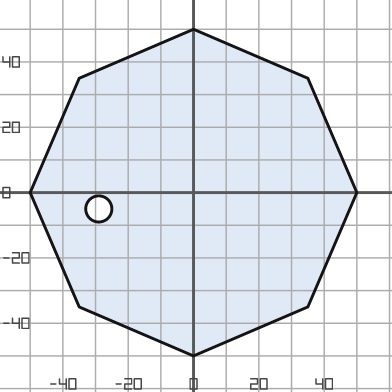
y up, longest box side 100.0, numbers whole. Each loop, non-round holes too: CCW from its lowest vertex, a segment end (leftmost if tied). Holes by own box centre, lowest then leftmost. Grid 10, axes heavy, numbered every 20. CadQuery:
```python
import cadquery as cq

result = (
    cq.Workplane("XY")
    .moveTo(0.0, -50.0)
    .lineTo(35.0, -35.0)
    .lineTo(50.0, 0.0)
    .lineTo(35.0, 35.0)
    .lineTo(0.0, 50.0)
    .lineTo(-35.0, 35.0)
    .lineTo(-50.0, 0.0)
    .lineTo(-35.0, -35.0)
    .close()
    .moveTo(-29.0, -5.0)
    .circle(4.0)
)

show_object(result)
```